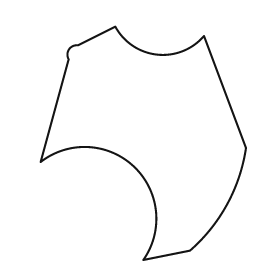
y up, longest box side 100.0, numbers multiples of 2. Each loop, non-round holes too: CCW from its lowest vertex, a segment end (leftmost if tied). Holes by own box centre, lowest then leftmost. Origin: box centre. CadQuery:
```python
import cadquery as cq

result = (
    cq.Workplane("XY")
    .moveTo(0.0, -50.0)
    .lineTo(20.0, -46.0)
    .threePointArc((36.0, -26.0), (44.0, -2.0))
    .lineTo(26.0, 46.0)
    .threePointArc((6.0, 38.0), (-12.0, 50.0))
    .lineTo(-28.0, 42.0)
    .threePointArc((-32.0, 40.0), (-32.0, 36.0))
    .lineTo(-44.0, -8.0)
    .threePointArc((-4.0, -10.0), (0.0, -50.0))
    .close()
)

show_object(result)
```